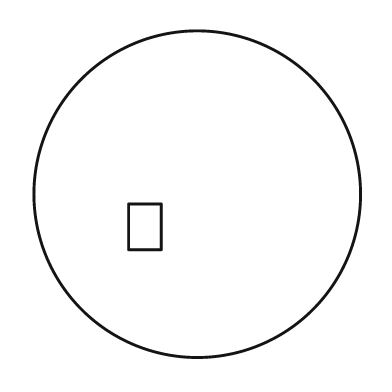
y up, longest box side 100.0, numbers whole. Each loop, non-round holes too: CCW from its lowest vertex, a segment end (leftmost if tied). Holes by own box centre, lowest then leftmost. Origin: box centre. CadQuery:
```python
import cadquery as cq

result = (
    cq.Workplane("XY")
    .moveTo(0.0, 0.0)
    .circle(50.0)
    .moveTo(-21.0, -17.0)
    .lineTo(-11.0, -17.0)
    .lineTo(-11.0, -3.0)
    .lineTo(-21.0, -3.0)
    .close()
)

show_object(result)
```